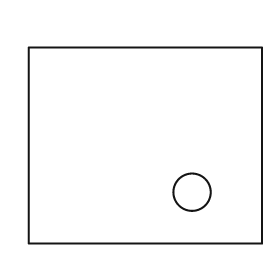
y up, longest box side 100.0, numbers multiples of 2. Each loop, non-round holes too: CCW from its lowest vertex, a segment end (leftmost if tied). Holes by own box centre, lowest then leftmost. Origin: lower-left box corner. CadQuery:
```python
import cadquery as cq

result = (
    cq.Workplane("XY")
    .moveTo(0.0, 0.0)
    .lineTo(100.0, 0.0)
    .lineTo(100.0, 84.0)
    .lineTo(0.0, 84.0)
    .close()
    .moveTo(70.0, 22.0)
    .circle(8.0)
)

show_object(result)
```